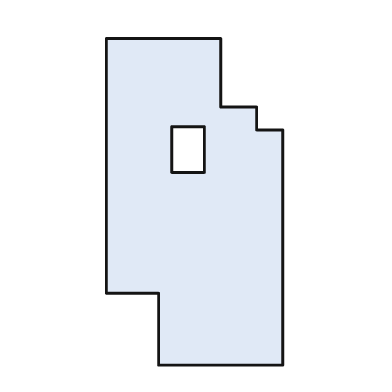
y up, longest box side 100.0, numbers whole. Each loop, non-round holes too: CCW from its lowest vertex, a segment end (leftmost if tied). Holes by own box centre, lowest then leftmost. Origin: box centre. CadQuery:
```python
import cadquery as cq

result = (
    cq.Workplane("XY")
    .moveTo(-11.0, -50.0)
    .lineTo(27.0, -50.0)
    .lineTo(27.0, 22.0)
    .lineTo(19.0, 22.0)
    .lineTo(19.0, 29.0)
    .lineTo(8.0, 29.0)
    .lineTo(8.0, 50.0)
    .lineTo(-27.0, 50.0)
    .lineTo(-27.0, -28.0)
    .lineTo(-11.0, -28.0)
    .close()
    .moveTo(-7.0, 9.0)
    .lineTo(3.0, 9.0)
    .lineTo(3.0, 23.0)
    .lineTo(-7.0, 23.0)
    .close()
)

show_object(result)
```